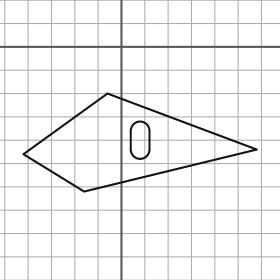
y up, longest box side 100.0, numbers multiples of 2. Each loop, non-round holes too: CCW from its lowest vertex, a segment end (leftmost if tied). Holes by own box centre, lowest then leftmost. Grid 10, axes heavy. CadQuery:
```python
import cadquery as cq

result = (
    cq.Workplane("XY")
    .moveTo(-16.0, -62.0)
    .lineTo(58.0, -44.0)
    .lineTo(-6.0, -20.0)
    .lineTo(-42.0, -46.0)
    .close()
    .moveTo(4.0, -44.0)
    .threePointArc((8.0, -48.0), (12.0, -44.0))
    .lineTo(12.0, -36.0)
    .threePointArc((8.0, -32.0), (4.0, -36.0))
    .close()
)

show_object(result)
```